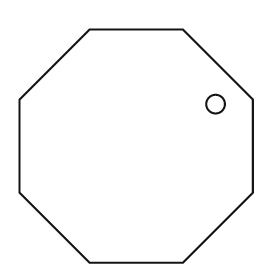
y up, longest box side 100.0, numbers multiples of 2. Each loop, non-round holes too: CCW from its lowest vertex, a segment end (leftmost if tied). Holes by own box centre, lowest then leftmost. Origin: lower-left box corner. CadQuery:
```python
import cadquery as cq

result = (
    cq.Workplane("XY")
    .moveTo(30.0, 0.0)
    .lineTo(70.0, 0.0)
    .lineTo(100.0, 30.0)
    .lineTo(100.0, 70.0)
    .lineTo(70.0, 100.0)
    .lineTo(30.0, 100.0)
    .lineTo(0.0, 70.0)
    .lineTo(0.0, 30.0)
    .close()
    .moveTo(84.0, 68.0)
    .circle(4.0)
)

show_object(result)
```